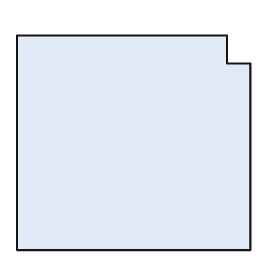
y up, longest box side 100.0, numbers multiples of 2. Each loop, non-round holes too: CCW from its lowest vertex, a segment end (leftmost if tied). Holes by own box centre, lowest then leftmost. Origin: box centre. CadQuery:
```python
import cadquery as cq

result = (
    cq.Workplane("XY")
    .moveTo(-50.0, -46.0)
    .lineTo(50.0, -46.0)
    .lineTo(50.0, 34.0)
    .lineTo(40.0, 34.0)
    .lineTo(40.0, 46.0)
    .lineTo(-50.0, 46.0)
    .close()
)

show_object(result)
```